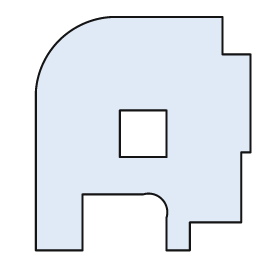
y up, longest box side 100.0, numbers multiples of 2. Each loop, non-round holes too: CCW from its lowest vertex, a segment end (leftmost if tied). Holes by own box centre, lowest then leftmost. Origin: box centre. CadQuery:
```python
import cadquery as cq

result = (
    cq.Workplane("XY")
    .moveTo(-46.0, -50.0)
    .lineTo(-26.0, -50.0)
    .lineTo(-26.0, -26.0)
    .lineTo(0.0, -26.0)
    .threePointArc((8.0, -28.0), (10.0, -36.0))
    .lineTo(10.0, -50.0)
    .lineTo(20.0, -50.0)
    .lineTo(20.0, -38.0)
    .lineTo(42.0, -38.0)
    .lineTo(42.0, -8.0)
    .lineTo(46.0, -8.0)
    .lineTo(46.0, 34.0)
    .lineTo(34.0, 34.0)
    .lineTo(34.0, 50.0)
    .lineTo(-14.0, 50.0)
    .threePointArc((-36.0, 40.0), (-46.0, 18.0))
    .close()
    .moveTo(-10.0, -10.0)
    .lineTo(10.0, -10.0)
    .lineTo(10.0, 10.0)
    .lineTo(-10.0, 10.0)
    .close()
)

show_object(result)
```